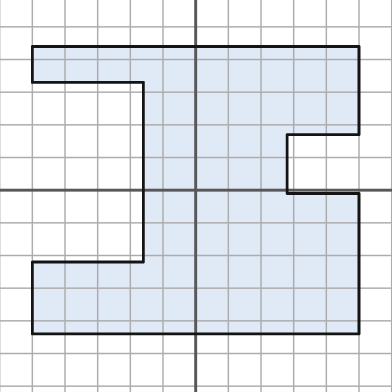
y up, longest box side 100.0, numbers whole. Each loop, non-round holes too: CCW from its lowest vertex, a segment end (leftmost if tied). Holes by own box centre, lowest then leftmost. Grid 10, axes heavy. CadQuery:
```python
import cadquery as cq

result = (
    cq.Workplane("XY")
    .moveTo(-50.0, -44.0)
    .lineTo(50.0, -44.0)
    .lineTo(50.0, -1.0)
    .lineTo(28.0, -1.0)
    .lineTo(28.0, 17.0)
    .lineTo(50.0, 17.0)
    .lineTo(50.0, 44.0)
    .lineTo(-50.0, 44.0)
    .lineTo(-50.0, 33.0)
    .lineTo(-16.0, 33.0)
    .lineTo(-16.0, -22.0)
    .lineTo(-50.0, -22.0)
    .close()
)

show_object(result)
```